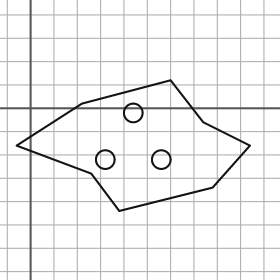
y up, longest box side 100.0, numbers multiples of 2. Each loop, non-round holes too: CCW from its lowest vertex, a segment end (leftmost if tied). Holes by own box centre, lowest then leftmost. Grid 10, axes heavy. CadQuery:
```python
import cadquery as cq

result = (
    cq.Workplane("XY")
    .moveTo(38.0, -44.0)
    .lineTo(78.0, -34.0)
    .lineTo(94.0, -16.0)
    .lineTo(74.0, -6.0)
    .lineTo(60.0, 12.0)
    .lineTo(22.0, 2.0)
    .lineTo(-6.0, -16.0)
    .lineTo(26.0, -28.0)
    .close()
    .moveTo(32.0, -22.0)
    .circle(4.0)
    .moveTo(56.0, -22.0)
    .circle(4.0)
    .moveTo(44.0, -2.0)
    .circle(4.0)
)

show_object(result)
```